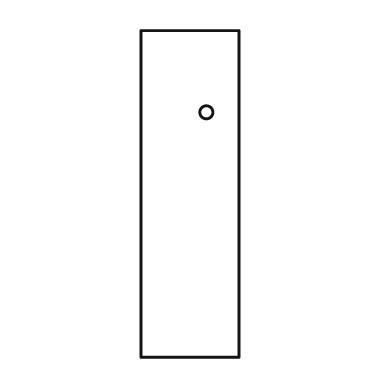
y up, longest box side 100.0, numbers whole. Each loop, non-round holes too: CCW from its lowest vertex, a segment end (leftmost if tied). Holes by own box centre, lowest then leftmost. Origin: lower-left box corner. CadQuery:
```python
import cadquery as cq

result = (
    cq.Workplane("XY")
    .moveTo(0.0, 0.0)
    .lineTo(30.0, 0.0)
    .lineTo(30.0, 100.0)
    .lineTo(0.0, 100.0)
    .close()
    .moveTo(20.0, 75.0)
    .circle(2.0)
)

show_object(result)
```